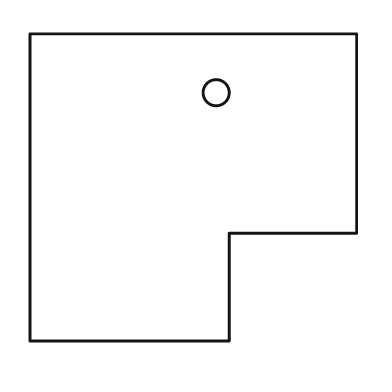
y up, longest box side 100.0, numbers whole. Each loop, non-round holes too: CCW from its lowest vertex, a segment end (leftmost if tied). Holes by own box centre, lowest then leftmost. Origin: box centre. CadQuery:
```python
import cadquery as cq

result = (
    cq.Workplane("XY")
    .moveTo(-50.0, -47.0)
    .lineTo(11.0, -47.0)
    .lineTo(11.0, -14.0)
    .lineTo(50.0, -14.0)
    .lineTo(50.0, 47.0)
    .lineTo(-50.0, 47.0)
    .close()
    .moveTo(7.0, 29.0)
    .circle(4.0)
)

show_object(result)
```